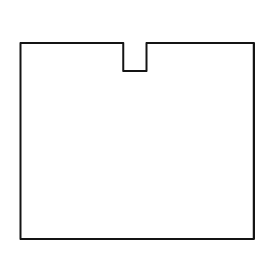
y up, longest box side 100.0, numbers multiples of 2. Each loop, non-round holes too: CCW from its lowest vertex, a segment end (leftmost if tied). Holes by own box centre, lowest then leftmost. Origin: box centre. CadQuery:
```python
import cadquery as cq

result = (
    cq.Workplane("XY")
    .moveTo(-50.0, -42.0)
    .lineTo(50.0, -42.0)
    .lineTo(50.0, 42.0)
    .lineTo(4.0, 42.0)
    .lineTo(4.0, 30.0)
    .lineTo(-6.0, 30.0)
    .lineTo(-6.0, 42.0)
    .lineTo(-50.0, 42.0)
    .close()
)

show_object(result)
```